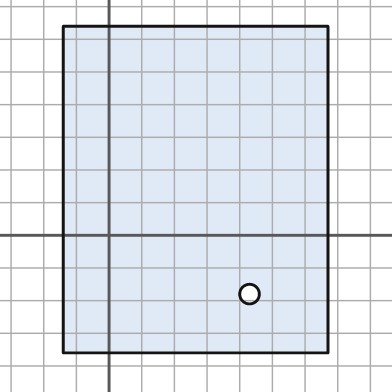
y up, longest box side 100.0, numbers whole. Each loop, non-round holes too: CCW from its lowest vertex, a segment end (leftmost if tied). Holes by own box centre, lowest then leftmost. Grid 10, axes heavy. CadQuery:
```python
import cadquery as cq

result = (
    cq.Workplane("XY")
    .moveTo(-14.0, -36.0)
    .lineTo(67.0, -36.0)
    .lineTo(67.0, 64.0)
    .lineTo(-14.0, 64.0)
    .close()
    .moveTo(43.0, -18.0)
    .circle(3.0)
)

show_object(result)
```